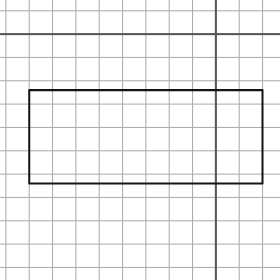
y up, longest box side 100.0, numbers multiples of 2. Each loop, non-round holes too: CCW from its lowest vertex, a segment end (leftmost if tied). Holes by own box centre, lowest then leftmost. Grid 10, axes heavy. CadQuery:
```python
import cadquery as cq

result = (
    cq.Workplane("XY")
    .moveTo(-80.0, -64.0)
    .lineTo(20.0, -64.0)
    .lineTo(20.0, -24.0)
    .lineTo(-80.0, -24.0)
    .close()
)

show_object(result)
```